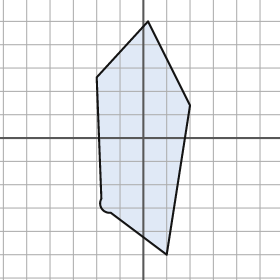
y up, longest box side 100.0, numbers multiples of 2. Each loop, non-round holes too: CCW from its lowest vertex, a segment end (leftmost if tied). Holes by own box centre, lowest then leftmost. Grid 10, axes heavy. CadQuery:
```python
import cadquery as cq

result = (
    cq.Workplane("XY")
    .moveTo(10.0, -50.0)
    .lineTo(20.0, 14.0)
    .lineTo(2.0, 50.0)
    .lineTo(-20.0, 26.0)
    .lineTo(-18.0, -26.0)
    .threePointArc((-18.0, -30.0), (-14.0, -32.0))
    .close()
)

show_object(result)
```